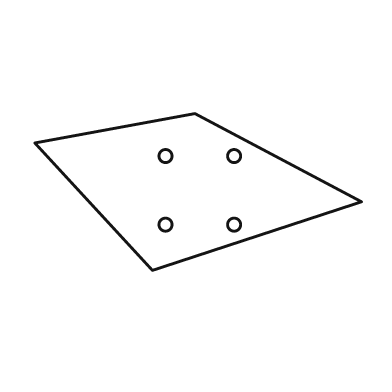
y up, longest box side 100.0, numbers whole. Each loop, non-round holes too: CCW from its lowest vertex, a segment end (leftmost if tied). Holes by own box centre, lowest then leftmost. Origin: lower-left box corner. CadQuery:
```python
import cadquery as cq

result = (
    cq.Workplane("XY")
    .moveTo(36.0, 0.0)
    .lineTo(100.0, 21.0)
    .lineTo(49.0, 48.0)
    .lineTo(0.0, 39.0)
    .close()
    .moveTo(40.0, 14.0)
    .circle(2.0)
    .moveTo(61.0, 14.0)
    .circle(2.0)
    .moveTo(40.0, 35.0)
    .circle(2.0)
    .moveTo(61.0, 35.0)
    .circle(2.0)
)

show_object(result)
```